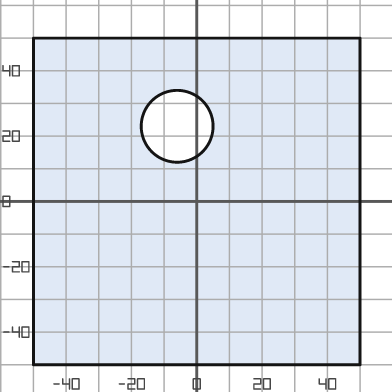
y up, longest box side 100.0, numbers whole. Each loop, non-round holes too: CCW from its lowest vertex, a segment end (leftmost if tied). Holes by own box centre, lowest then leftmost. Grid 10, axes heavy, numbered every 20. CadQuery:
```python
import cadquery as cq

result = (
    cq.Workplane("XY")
    .moveTo(-50.0, -50.0)
    .lineTo(50.0, -50.0)
    .lineTo(50.0, 50.0)
    .lineTo(-50.0, 50.0)
    .close()
    .moveTo(-6.0, 23.0)
    .circle(11.0)
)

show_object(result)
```